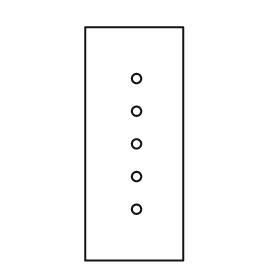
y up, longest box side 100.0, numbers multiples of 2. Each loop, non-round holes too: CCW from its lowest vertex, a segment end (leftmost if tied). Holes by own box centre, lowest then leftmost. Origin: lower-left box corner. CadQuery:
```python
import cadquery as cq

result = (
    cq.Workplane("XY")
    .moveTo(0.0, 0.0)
    .lineTo(42.0, 0.0)
    .lineTo(42.0, 100.0)
    .lineTo(0.0, 100.0)
    .close()
    .moveTo(22.0, 22.0)
    .circle(2.0)
    .moveTo(22.0, 36.0)
    .circle(2.0)
    .moveTo(22.0, 50.0)
    .circle(2.0)
    .moveTo(22.0, 64.0)
    .circle(2.0)
    .moveTo(22.0, 78.0)
    .circle(2.0)
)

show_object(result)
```